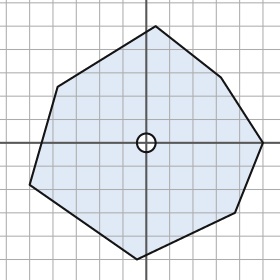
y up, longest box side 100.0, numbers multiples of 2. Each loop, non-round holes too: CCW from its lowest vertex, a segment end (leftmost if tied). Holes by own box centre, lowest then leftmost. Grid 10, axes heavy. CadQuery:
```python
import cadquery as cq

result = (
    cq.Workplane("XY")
    .moveTo(-4.0, -50.0)
    .lineTo(38.0, -30.0)
    .lineTo(50.0, 0.0)
    .lineTo(32.0, 28.0)
    .lineTo(4.0, 50.0)
    .lineTo(-38.0, 24.0)
    .lineTo(-50.0, -18.0)
    .close()
    .moveTo(0.0, 0.0)
    .circle(4.0)
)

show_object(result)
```